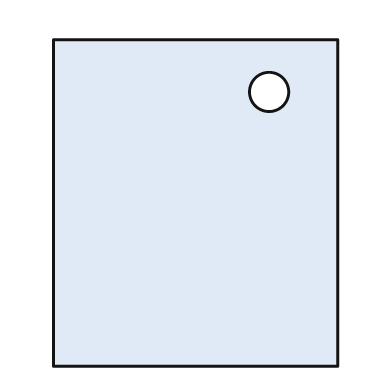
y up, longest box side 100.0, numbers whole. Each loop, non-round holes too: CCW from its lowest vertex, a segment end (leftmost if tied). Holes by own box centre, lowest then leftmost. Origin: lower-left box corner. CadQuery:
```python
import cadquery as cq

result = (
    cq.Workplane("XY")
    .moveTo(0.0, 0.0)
    .lineTo(87.0, 0.0)
    .lineTo(87.0, 100.0)
    .lineTo(0.0, 100.0)
    .close()
    .moveTo(66.0, 84.0)
    .circle(6.0)
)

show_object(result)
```